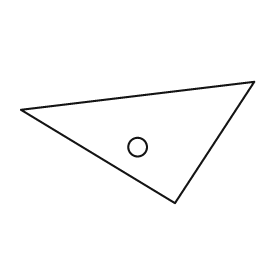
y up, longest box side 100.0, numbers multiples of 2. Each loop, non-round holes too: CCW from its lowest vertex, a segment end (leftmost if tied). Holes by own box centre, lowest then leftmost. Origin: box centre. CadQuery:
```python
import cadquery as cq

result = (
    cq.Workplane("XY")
    .moveTo(16.0, -26.0)
    .lineTo(50.0, 26.0)
    .lineTo(-50.0, 14.0)
    .close()
    .moveTo(0.0, -2.0)
    .circle(4.0)
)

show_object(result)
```